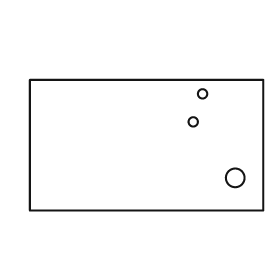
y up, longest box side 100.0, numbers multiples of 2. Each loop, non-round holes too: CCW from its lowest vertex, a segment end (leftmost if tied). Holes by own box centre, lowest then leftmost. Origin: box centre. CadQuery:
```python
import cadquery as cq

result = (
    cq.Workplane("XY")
    .moveTo(-50.0, -28.0)
    .lineTo(50.0, -28.0)
    .lineTo(50.0, 28.0)
    .lineTo(-50.0, 28.0)
    .close()
    .moveTo(38.0, -14.0)
    .circle(4.0)
    .moveTo(20.0, 10.0)
    .circle(2.0)
    .moveTo(24.0, 22.0)
    .circle(2.0)
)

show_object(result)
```